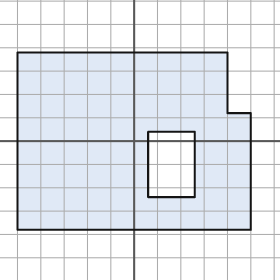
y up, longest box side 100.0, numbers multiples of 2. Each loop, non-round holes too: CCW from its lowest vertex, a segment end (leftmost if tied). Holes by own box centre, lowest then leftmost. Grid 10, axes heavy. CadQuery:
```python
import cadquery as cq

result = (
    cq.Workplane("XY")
    .moveTo(-50.0, -38.0)
    .lineTo(50.0, -38.0)
    .lineTo(50.0, 12.0)
    .lineTo(40.0, 12.0)
    .lineTo(40.0, 38.0)
    .lineTo(-50.0, 38.0)
    .close()
    .moveTo(6.0, -24.0)
    .lineTo(26.0, -24.0)
    .lineTo(26.0, 4.0)
    .lineTo(6.0, 4.0)
    .close()
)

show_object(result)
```